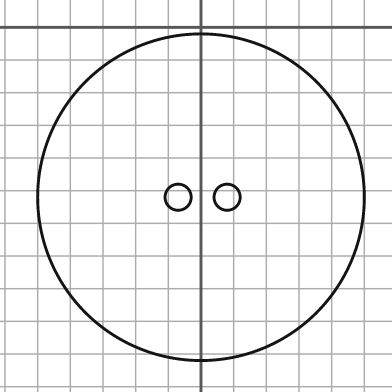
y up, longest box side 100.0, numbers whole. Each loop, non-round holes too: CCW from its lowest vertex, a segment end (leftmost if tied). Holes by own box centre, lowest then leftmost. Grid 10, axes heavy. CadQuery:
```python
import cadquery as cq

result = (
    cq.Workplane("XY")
    .moveTo(0.0, -52.0)
    .circle(50.0)
    .moveTo(-7.0, -52.0)
    .circle(4.0)
    .moveTo(8.0, -52.0)
    .circle(4.0)
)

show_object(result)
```